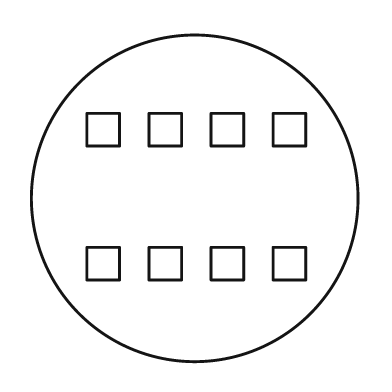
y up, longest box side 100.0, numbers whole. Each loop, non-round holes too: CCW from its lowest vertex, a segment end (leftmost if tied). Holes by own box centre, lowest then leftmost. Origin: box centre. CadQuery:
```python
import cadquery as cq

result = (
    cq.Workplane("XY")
    .moveTo(0.0, 0.0)
    .circle(50.0)
    .moveTo(-33.0, -25.0)
    .lineTo(-23.0, -25.0)
    .lineTo(-23.0, -15.0)
    .lineTo(-33.0, -15.0)
    .close()
    .moveTo(-14.0, -25.0)
    .lineTo(-4.0, -25.0)
    .lineTo(-4.0, -15.0)
    .lineTo(-14.0, -15.0)
    .close()
    .moveTo(5.0, -25.0)
    .lineTo(15.0, -25.0)
    .lineTo(15.0, -15.0)
    .lineTo(5.0, -15.0)
    .close()
    .moveTo(24.0, -25.0)
    .lineTo(34.0, -25.0)
    .lineTo(34.0, -15.0)
    .lineTo(24.0, -15.0)
    .close()
    .moveTo(-33.0, 16.0)
    .lineTo(-23.0, 16.0)
    .lineTo(-23.0, 26.0)
    .lineTo(-33.0, 26.0)
    .close()
    .moveTo(-14.0, 16.0)
    .lineTo(-4.0, 16.0)
    .lineTo(-4.0, 26.0)
    .lineTo(-14.0, 26.0)
    .close()
    .moveTo(5.0, 16.0)
    .lineTo(15.0, 16.0)
    .lineTo(15.0, 26.0)
    .lineTo(5.0, 26.0)
    .close()
    .moveTo(24.0, 16.0)
    .lineTo(34.0, 16.0)
    .lineTo(34.0, 26.0)
    .lineTo(24.0, 26.0)
    .close()
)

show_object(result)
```